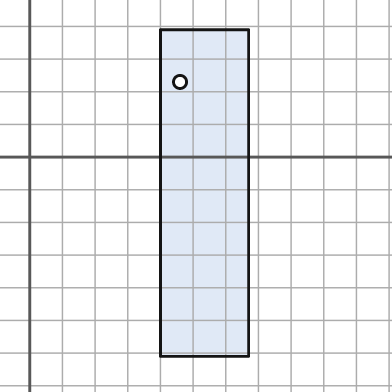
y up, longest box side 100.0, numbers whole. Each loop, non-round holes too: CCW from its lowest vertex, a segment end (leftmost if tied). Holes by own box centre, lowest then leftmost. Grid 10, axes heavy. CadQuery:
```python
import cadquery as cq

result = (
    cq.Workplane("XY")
    .moveTo(40.0, -61.0)
    .lineTo(67.0, -61.0)
    .lineTo(67.0, 39.0)
    .lineTo(40.0, 39.0)
    .close()
    .moveTo(46.0, 23.0)
    .circle(2.0)
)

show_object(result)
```